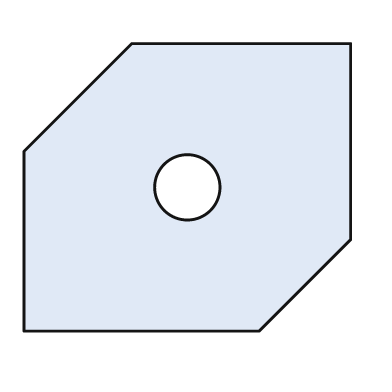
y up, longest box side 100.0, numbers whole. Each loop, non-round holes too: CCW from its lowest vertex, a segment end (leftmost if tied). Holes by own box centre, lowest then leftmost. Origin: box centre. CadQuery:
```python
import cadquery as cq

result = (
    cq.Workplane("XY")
    .moveTo(-50.0, -44.0)
    .lineTo(22.0, -44.0)
    .lineTo(50.0, -16.0)
    .lineTo(50.0, 44.0)
    .lineTo(-17.0, 44.0)
    .lineTo(-50.0, 11.0)
    .close()
    .moveTo(0.0, 0.0)
    .circle(10.0)
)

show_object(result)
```